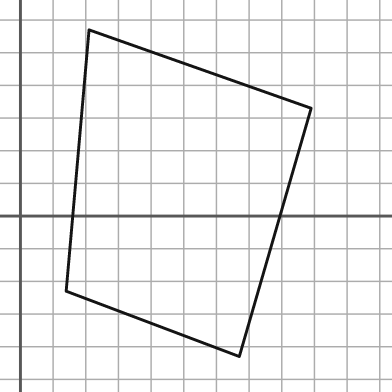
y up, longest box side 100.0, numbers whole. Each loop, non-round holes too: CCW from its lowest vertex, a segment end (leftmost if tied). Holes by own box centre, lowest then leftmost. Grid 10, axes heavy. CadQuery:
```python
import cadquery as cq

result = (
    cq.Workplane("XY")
    .moveTo(67.0, -43.0)
    .lineTo(89.0, 33.0)
    .lineTo(21.0, 57.0)
    .lineTo(14.0, -23.0)
    .close()
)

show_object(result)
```